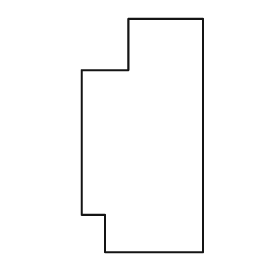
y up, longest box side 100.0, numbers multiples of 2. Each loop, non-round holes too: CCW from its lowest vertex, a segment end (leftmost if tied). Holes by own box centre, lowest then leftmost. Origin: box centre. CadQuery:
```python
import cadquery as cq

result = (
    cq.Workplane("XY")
    .moveTo(-16.0, -50.0)
    .lineTo(26.0, -50.0)
    .lineTo(26.0, 50.0)
    .lineTo(-6.0, 50.0)
    .lineTo(-6.0, 28.0)
    .lineTo(-26.0, 28.0)
    .lineTo(-26.0, -34.0)
    .lineTo(-16.0, -34.0)
    .close()
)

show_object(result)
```